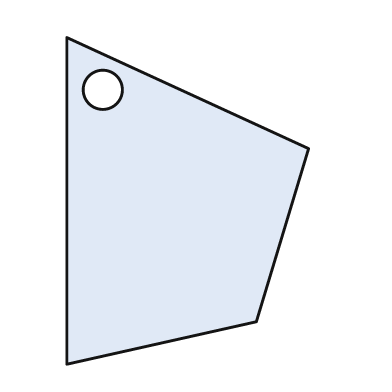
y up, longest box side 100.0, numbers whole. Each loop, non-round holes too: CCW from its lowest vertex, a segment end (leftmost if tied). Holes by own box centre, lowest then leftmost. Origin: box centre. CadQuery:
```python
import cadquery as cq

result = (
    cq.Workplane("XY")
    .moveTo(-37.0, -50.0)
    .lineTo(21.0, -37.0)
    .lineTo(37.0, 16.0)
    .lineTo(-37.0, 50.0)
    .close()
    .moveTo(-26.0, 34.0)
    .circle(6.0)
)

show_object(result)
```